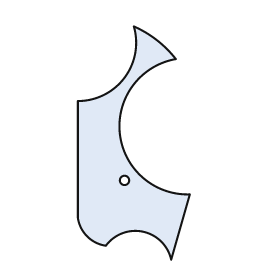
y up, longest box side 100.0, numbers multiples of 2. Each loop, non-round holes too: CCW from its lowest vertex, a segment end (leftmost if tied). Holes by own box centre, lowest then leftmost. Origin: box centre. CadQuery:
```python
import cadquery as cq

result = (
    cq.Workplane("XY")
    .moveTo(16.0, -50.0)
    .lineTo(24.0, -22.0)
    .threePointArc((-6.0, 4.0), (18.0, 36.0))
    .threePointArc((10.0, 44.0), (0.0, 50.0))
    .threePointArc((-4.0, 28.0), (-24.0, 18.0))
    .lineTo(-24.0, -32.0)
    .threePointArc((-20.0, -40.0), (-12.0, -44.0))
    .threePointArc((4.0, -38.0), (16.0, -50.0))
    .close()
    .moveTo(-4.0, -16.0)
    .circle(2.0)
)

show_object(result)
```